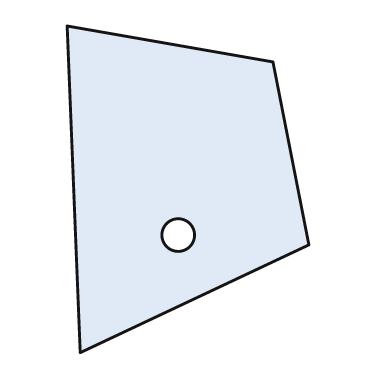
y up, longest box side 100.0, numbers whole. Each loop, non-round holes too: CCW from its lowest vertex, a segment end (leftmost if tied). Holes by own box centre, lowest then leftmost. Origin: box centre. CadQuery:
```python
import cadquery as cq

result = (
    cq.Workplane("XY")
    .moveTo(-33.0, -50.0)
    .lineTo(37.0, -17.0)
    .lineTo(26.0, 39.0)
    .lineTo(-37.0, 50.0)
    .close()
    .moveTo(-3.0, -14.0)
    .circle(5.0)
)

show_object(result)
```